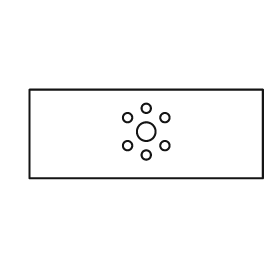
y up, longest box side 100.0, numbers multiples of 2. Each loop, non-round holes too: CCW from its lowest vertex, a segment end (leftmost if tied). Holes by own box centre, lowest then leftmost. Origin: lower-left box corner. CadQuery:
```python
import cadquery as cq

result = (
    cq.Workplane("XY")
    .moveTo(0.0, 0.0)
    .lineTo(100.0, 0.0)
    .lineTo(100.0, 38.0)
    .lineTo(0.0, 38.0)
    .close()
    .moveTo(50.0, 10.0)
    .circle(2.0)
    .moveTo(42.0, 14.0)
    .circle(2.0)
    .moveTo(58.0, 14.0)
    .circle(2.0)
    .moveTo(50.0, 20.0)
    .circle(4.0)
    .moveTo(42.0, 26.0)
    .circle(2.0)
    .moveTo(58.0, 26.0)
    .circle(2.0)
    .moveTo(50.0, 30.0)
    .circle(2.0)
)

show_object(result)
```